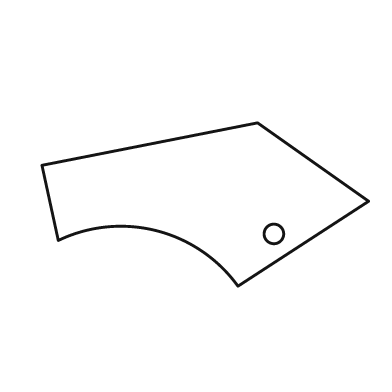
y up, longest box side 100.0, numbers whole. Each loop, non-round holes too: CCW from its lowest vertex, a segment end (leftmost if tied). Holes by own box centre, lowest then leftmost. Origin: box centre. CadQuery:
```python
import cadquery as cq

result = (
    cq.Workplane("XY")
    .moveTo(10.0, -25.0)
    .lineTo(50.0, 1.0)
    .lineTo(16.0, 25.0)
    .lineTo(-50.0, 12.0)
    .lineTo(-45.0, -11.0)
    .threePointArc((-15.0, -8.0), (10.0, -25.0))
    .close()
    .moveTo(21.0, -9.0)
    .circle(3.0)
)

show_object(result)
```